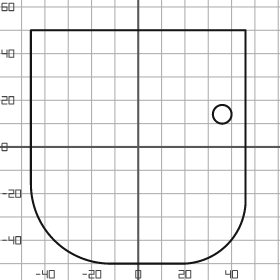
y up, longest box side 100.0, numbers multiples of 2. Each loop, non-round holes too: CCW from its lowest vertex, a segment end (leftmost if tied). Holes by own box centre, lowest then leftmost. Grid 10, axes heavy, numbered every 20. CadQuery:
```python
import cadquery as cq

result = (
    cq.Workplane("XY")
    .moveTo(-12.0, -50.0)
    .lineTo(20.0, -50.0)
    .threePointArc((38.0, -42.0), (46.0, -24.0))
    .lineTo(46.0, 50.0)
    .lineTo(-46.0, 50.0)
    .lineTo(-46.0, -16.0)
    .threePointArc((-36.0, -40.0), (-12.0, -50.0))
    .close()
    .moveTo(36.0, 14.0)
    .circle(4.0)
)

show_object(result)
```